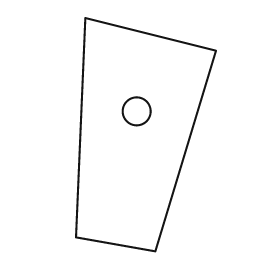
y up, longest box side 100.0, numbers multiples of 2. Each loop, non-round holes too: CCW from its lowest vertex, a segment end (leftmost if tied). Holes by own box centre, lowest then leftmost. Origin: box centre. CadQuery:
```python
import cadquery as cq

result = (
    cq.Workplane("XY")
    .moveTo(4.0, -50.0)
    .lineTo(30.0, 36.0)
    .lineTo(-26.0, 50.0)
    .lineTo(-30.0, -44.0)
    .close()
    .moveTo(-4.0, 10.0)
    .circle(6.0)
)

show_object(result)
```